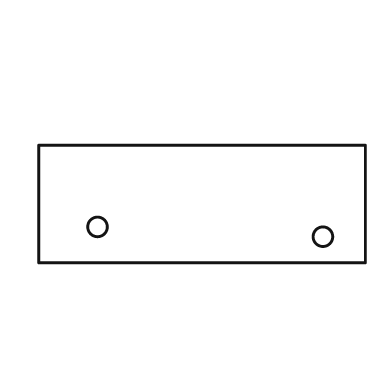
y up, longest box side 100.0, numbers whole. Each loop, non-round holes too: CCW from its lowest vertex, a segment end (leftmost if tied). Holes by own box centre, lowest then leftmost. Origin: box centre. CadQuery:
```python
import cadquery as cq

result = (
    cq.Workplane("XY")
    .moveTo(-50.0, -18.0)
    .lineTo(50.0, -18.0)
    .lineTo(50.0, 18.0)
    .lineTo(-50.0, 18.0)
    .close()
    .moveTo(37.0, -10.0)
    .circle(3.0)
    .moveTo(-32.0, -7.0)
    .circle(3.0)
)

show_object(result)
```